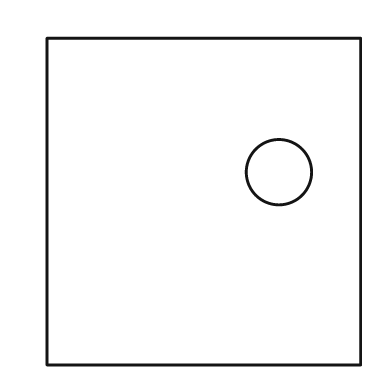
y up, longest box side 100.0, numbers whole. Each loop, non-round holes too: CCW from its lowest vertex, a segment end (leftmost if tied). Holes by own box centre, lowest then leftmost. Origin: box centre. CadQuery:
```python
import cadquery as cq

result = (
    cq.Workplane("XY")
    .moveTo(-48.0, -50.0)
    .lineTo(48.0, -50.0)
    .lineTo(48.0, 50.0)
    .lineTo(-48.0, 50.0)
    .close()
    .moveTo(23.0, 9.0)
    .circle(10.0)
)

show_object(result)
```